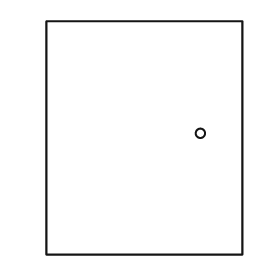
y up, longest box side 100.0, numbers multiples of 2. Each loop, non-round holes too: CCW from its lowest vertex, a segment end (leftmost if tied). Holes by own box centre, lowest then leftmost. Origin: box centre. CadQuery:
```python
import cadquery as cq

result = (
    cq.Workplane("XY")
    .moveTo(-42.0, -50.0)
    .lineTo(42.0, -50.0)
    .lineTo(42.0, 50.0)
    .lineTo(-42.0, 50.0)
    .close()
    .moveTo(24.0, 2.0)
    .circle(2.0)
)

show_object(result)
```